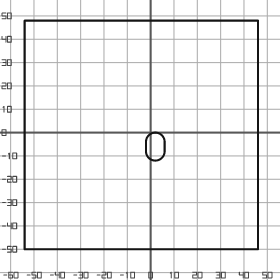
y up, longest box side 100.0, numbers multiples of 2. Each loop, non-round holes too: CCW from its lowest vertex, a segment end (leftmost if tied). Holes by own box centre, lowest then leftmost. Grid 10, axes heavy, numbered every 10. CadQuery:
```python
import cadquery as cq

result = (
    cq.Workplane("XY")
    .moveTo(-54.0, -50.0)
    .lineTo(46.0, -50.0)
    .lineTo(46.0, 48.0)
    .lineTo(-54.0, 48.0)
    .close()
    .moveTo(-2.0, -8.0)
    .threePointArc((2.0, -12.0), (6.0, -8.0))
    .lineTo(6.0, -4.0)
    .threePointArc((2.0, 0.0), (-2.0, -4.0))
    .close()
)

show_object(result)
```